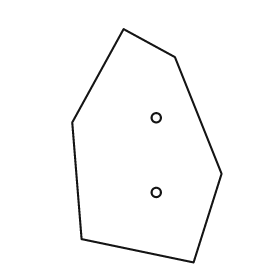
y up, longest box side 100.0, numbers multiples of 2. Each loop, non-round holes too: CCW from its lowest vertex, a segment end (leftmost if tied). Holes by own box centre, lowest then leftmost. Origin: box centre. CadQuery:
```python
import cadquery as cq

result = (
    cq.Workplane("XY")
    .moveTo(20.0, -50.0)
    .lineTo(32.0, -12.0)
    .lineTo(12.0, 38.0)
    .lineTo(-10.0, 50.0)
    .lineTo(-32.0, 10.0)
    .lineTo(-28.0, -40.0)
    .close()
    .moveTo(4.0, -20.0)
    .circle(2.0)
    .moveTo(4.0, 12.0)
    .circle(2.0)
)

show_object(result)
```